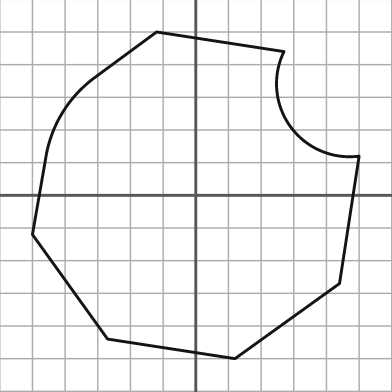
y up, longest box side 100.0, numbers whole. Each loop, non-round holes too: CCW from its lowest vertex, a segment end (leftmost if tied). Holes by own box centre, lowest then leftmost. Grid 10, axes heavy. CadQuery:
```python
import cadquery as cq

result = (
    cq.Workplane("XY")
    .moveTo(12.0, -50.0)
    .lineTo(44.0, -27.0)
    .lineTo(50.0, 12.0)
    .threePointArc((29.0, 21.0), (27.0, 44.0))
    .lineTo(-12.0, 50.0)
    .lineTo(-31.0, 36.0)
    .threePointArc((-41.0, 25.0), (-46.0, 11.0))
    .lineTo(-50.0, -12.0)
    .lineTo(-27.0, -44.0)
    .close()
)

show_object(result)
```